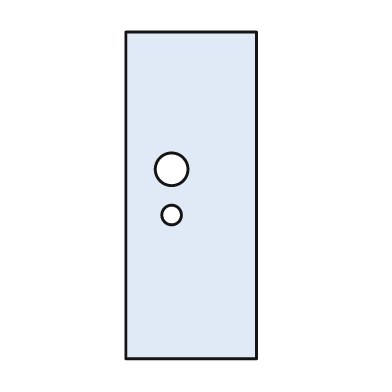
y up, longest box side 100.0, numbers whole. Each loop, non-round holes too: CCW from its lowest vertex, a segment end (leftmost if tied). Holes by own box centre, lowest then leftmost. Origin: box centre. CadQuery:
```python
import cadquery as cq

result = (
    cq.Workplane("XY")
    .moveTo(-20.0, -50.0)
    .lineTo(20.0, -50.0)
    .lineTo(20.0, 50.0)
    .lineTo(-20.0, 50.0)
    .close()
    .moveTo(-6.0, -6.0)
    .circle(3.0)
    .moveTo(-6.0, 8.0)
    .circle(5.0)
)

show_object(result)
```